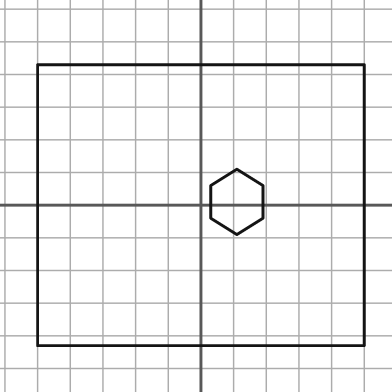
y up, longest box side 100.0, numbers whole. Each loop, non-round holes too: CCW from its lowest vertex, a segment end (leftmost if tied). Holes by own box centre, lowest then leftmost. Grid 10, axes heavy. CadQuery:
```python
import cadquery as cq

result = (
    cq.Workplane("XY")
    .moveTo(-50.0, -43.0)
    .lineTo(50.0, -43.0)
    .lineTo(50.0, 43.0)
    .lineTo(-50.0, 43.0)
    .close()
    .moveTo(11.0, -9.0)
    .lineTo(19.0, -4.0)
    .lineTo(19.0, 6.0)
    .lineTo(11.0, 11.0)
    .lineTo(3.0, 6.0)
    .lineTo(3.0, -4.0)
    .close()
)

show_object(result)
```